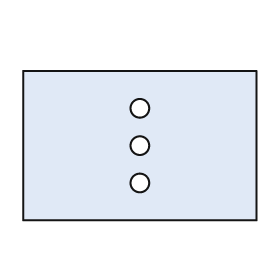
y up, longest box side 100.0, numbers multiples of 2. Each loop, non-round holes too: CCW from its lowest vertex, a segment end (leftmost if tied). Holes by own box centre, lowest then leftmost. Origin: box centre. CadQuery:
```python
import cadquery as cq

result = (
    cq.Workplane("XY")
    .moveTo(-50.0, -32.0)
    .lineTo(50.0, -32.0)
    .lineTo(50.0, 32.0)
    .lineTo(-50.0, 32.0)
    .close()
    .moveTo(0.0, -16.0)
    .circle(4.0)
    .moveTo(0.0, 0.0)
    .circle(4.0)
    .moveTo(0.0, 16.0)
    .circle(4.0)
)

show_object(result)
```